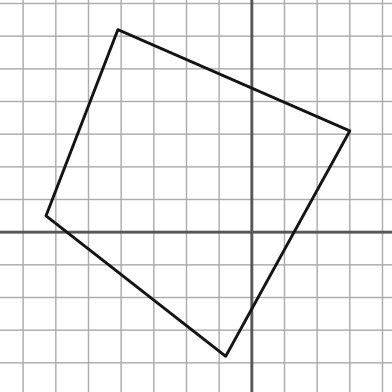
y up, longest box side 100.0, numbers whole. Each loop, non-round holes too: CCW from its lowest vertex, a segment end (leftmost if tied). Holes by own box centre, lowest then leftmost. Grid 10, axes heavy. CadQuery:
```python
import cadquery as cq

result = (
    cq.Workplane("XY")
    .moveTo(-8.0, -38.0)
    .lineTo(30.0, 31.0)
    .lineTo(-41.0, 62.0)
    .lineTo(-63.0, 5.0)
    .close()
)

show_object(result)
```